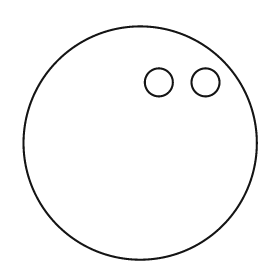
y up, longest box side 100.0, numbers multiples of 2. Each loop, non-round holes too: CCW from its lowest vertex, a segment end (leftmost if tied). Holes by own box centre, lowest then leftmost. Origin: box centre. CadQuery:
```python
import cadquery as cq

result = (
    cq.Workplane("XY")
    .moveTo(0.0, 0.0)
    .circle(50.0)
    .moveTo(8.0, 26.0)
    .circle(6.0)
    .moveTo(28.0, 26.0)
    .circle(6.0)
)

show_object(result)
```